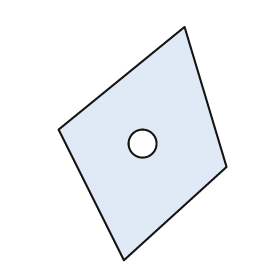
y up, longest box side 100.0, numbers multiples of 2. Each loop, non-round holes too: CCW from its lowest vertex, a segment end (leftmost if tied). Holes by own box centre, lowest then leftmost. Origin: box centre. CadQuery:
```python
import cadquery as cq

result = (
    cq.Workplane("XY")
    .moveTo(-8.0, -50.0)
    .lineTo(36.0, -10.0)
    .lineTo(18.0, 50.0)
    .lineTo(-36.0, 6.0)
    .close()
    .moveTo(0.0, 0.0)
    .circle(6.0)
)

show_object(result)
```